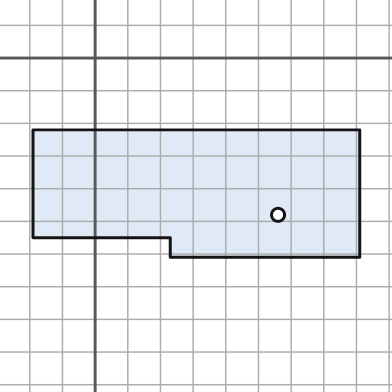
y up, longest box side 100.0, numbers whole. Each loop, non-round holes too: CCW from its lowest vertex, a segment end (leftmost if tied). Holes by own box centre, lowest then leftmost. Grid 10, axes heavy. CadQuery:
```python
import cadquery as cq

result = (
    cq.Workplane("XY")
    .moveTo(23.0, -61.0)
    .lineTo(81.0, -61.0)
    .lineTo(81.0, -22.0)
    .lineTo(-19.0, -22.0)
    .lineTo(-19.0, -55.0)
    .lineTo(23.0, -55.0)
    .close()
    .moveTo(56.0, -48.0)
    .circle(2.0)
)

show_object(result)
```